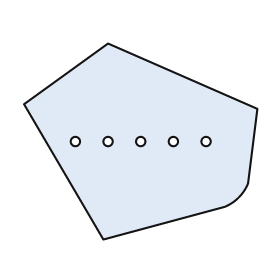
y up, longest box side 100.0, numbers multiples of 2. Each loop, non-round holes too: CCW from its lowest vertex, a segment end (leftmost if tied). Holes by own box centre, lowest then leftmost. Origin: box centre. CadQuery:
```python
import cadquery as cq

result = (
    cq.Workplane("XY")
    .moveTo(-16.0, -42.0)
    .lineTo(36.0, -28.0)
    .threePointArc((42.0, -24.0), (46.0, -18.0))
    .lineTo(50.0, 14.0)
    .lineTo(-14.0, 42.0)
    .lineTo(-50.0, 16.0)
    .close()
    .moveTo(-28.0, 0.0)
    .circle(2.0)
    .moveTo(-14.0, 0.0)
    .circle(2.0)
    .moveTo(0.0, 0.0)
    .circle(2.0)
    .moveTo(14.0, 0.0)
    .circle(2.0)
    .moveTo(28.0, 0.0)
    .circle(2.0)
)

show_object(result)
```